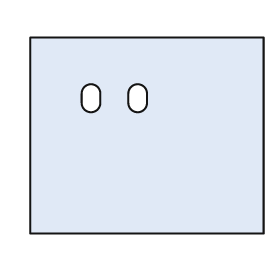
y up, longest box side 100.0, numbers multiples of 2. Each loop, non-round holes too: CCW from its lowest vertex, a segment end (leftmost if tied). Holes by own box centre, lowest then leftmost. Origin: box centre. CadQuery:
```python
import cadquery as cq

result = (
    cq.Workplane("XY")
    .moveTo(-50.0, -42.0)
    .lineTo(50.0, -42.0)
    .lineTo(50.0, 42.0)
    .lineTo(-50.0, 42.0)
    .close()
    .moveTo(-28.0, 14.0)
    .threePointArc((-24.0, 10.0), (-20.0, 14.0))
    .lineTo(-20.0, 18.0)
    .threePointArc((-24.0, 22.0), (-28.0, 18.0))
    .close()
    .moveTo(-8.0, 14.0)
    .threePointArc((-4.0, 10.0), (0.0, 14.0))
    .lineTo(0.0, 18.0)
    .threePointArc((-4.0, 22.0), (-8.0, 18.0))
    .close()
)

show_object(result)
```